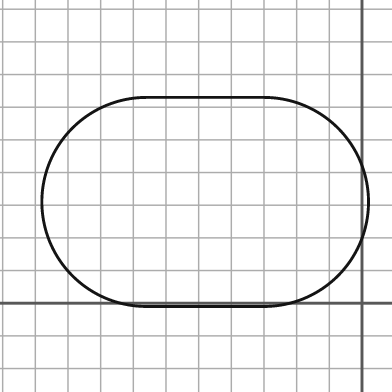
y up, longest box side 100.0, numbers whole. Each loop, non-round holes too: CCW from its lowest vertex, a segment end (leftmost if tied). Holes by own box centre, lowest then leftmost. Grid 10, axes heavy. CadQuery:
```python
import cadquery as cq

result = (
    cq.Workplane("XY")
    .moveTo(-66.0, -1.0)
    .lineTo(-30.0, -1.0)
    .threePointArc((2.0, 31.0), (-30.0, 63.0))
    .lineTo(-66.0, 63.0)
    .threePointArc((-98.0, 31.0), (-66.0, -1.0))
    .close()
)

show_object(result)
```